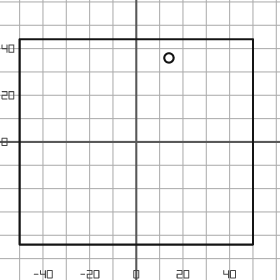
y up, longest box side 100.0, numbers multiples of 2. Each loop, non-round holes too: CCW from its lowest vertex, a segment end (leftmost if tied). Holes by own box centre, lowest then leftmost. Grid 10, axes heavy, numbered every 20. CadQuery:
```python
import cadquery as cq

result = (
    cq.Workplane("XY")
    .moveTo(-50.0, -44.0)
    .lineTo(50.0, -44.0)
    .lineTo(50.0, 44.0)
    .lineTo(-50.0, 44.0)
    .close()
    .moveTo(14.0, 36.0)
    .circle(2.0)
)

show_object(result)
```